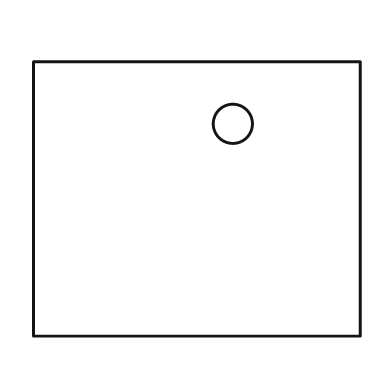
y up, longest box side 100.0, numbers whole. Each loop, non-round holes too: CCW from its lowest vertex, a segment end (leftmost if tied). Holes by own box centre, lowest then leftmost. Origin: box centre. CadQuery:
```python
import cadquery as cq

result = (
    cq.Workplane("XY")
    .moveTo(-50.0, -42.0)
    .lineTo(50.0, -42.0)
    .lineTo(50.0, 42.0)
    .lineTo(-50.0, 42.0)
    .close()
    .moveTo(11.0, 23.0)
    .circle(6.0)
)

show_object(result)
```